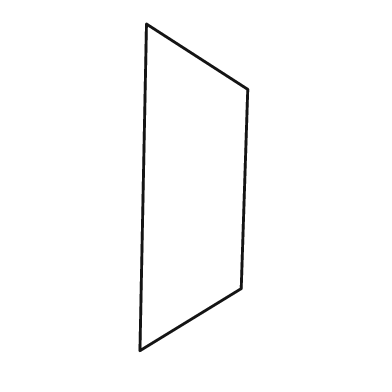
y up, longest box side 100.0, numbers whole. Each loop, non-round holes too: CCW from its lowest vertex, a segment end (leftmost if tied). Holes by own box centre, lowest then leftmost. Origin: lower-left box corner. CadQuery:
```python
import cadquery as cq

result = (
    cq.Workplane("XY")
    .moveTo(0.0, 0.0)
    .lineTo(31.0, 19.0)
    .lineTo(33.0, 80.0)
    .lineTo(2.0, 100.0)
    .close()
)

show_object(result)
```